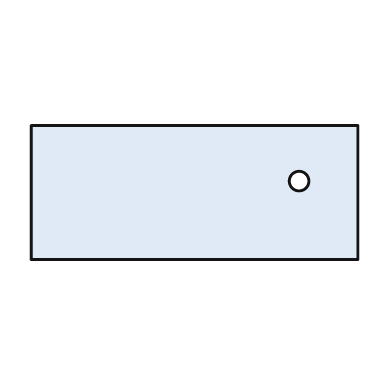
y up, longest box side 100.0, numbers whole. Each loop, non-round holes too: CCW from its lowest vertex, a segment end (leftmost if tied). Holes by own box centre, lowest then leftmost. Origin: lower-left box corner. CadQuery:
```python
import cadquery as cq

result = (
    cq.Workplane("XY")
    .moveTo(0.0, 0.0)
    .lineTo(100.0, 0.0)
    .lineTo(100.0, 41.0)
    .lineTo(0.0, 41.0)
    .close()
    .moveTo(82.0, 24.0)
    .circle(3.0)
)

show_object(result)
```